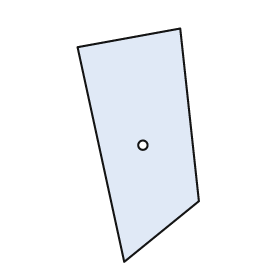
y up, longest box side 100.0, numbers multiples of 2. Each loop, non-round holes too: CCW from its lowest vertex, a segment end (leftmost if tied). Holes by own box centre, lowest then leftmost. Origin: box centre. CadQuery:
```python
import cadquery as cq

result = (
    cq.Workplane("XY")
    .moveTo(-6.0, -50.0)
    .lineTo(26.0, -24.0)
    .lineTo(18.0, 50.0)
    .lineTo(-26.0, 42.0)
    .close()
    .moveTo(2.0, 0.0)
    .circle(2.0)
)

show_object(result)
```